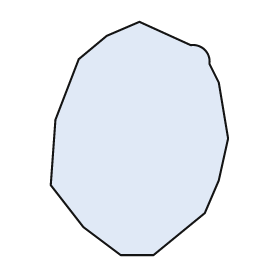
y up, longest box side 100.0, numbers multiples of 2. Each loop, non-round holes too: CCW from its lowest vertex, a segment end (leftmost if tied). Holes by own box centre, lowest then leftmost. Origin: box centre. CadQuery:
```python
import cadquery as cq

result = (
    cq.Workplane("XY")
    .moveTo(-8.0, -50.0)
    .lineTo(6.0, -50.0)
    .lineTo(28.0, -32.0)
    .lineTo(34.0, -18.0)
    .lineTo(38.0, 0.0)
    .lineTo(34.0, 24.0)
    .lineTo(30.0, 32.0)
    .threePointArc((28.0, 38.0), (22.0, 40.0))
    .lineTo(0.0, 50.0)
    .lineTo(-14.0, 44.0)
    .lineTo(-26.0, 34.0)
    .lineTo(-36.0, 8.0)
    .lineTo(-38.0, -20.0)
    .lineTo(-24.0, -38.0)
    .close()
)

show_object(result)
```